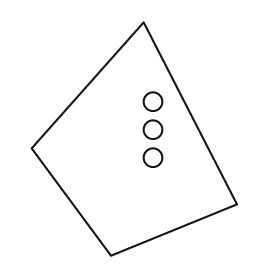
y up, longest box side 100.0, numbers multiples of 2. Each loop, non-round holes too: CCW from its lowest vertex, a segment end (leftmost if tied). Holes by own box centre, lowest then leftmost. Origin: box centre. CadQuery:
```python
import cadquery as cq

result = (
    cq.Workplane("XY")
    .moveTo(-10.0, -50.0)
    .lineTo(44.0, -28.0)
    .lineTo(4.0, 50.0)
    .lineTo(-44.0, -4.0)
    .close()
    .moveTo(8.0, -8.0)
    .circle(4.0)
    .moveTo(8.0, 4.0)
    .circle(4.0)
    .moveTo(8.0, 16.0)
    .circle(4.0)
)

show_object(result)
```